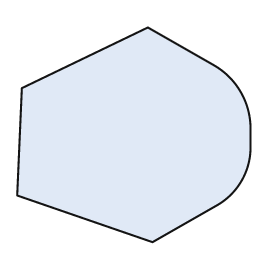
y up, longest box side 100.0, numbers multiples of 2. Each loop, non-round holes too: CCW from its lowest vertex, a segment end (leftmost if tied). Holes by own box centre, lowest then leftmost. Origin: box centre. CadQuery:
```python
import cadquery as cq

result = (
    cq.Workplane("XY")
    .moveTo(8.0, -46.0)
    .lineTo(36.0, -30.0)
    .threePointArc((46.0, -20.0), (50.0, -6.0))
    .lineTo(50.0, 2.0)
    .threePointArc((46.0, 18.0), (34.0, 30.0))
    .lineTo(6.0, 46.0)
    .lineTo(-48.0, 20.0)
    .lineTo(-50.0, -26.0)
    .close()
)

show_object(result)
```